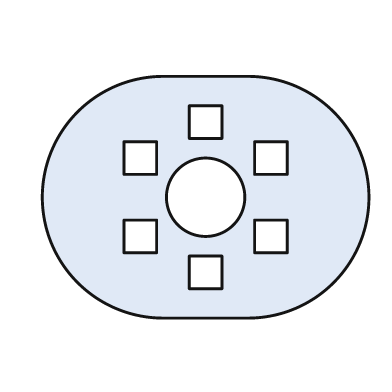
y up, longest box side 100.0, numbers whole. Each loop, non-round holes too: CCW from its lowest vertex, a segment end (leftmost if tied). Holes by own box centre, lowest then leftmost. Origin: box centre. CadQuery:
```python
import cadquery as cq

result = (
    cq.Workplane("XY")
    .moveTo(-13.0, -37.0)
    .lineTo(13.0, -37.0)
    .threePointArc((50.0, 0.0), (13.0, 37.0))
    .lineTo(-13.0, 37.0)
    .threePointArc((-50.0, 0.0), (-13.0, -37.0))
    .close()
    .moveTo(-5.0, -28.0)
    .lineTo(5.0, -28.0)
    .lineTo(5.0, -18.0)
    .lineTo(-5.0, -18.0)
    .close()
    .moveTo(-25.0, -17.0)
    .lineTo(-15.0, -17.0)
    .lineTo(-15.0, -7.0)
    .lineTo(-25.0, -7.0)
    .close()
    .moveTo(15.0, -17.0)
    .lineTo(25.0, -17.0)
    .lineTo(25.0, -7.0)
    .lineTo(15.0, -7.0)
    .close()
    .moveTo(0.0, 0.0)
    .circle(12.0)
    .moveTo(-25.0, 7.0)
    .lineTo(-15.0, 7.0)
    .lineTo(-15.0, 17.0)
    .lineTo(-25.0, 17.0)
    .close()
    .moveTo(15.0, 7.0)
    .lineTo(25.0, 7.0)
    .lineTo(25.0, 17.0)
    .lineTo(15.0, 17.0)
    .close()
    .moveTo(-5.0, 18.0)
    .lineTo(5.0, 18.0)
    .lineTo(5.0, 28.0)
    .lineTo(-5.0, 28.0)
    .close()
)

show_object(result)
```